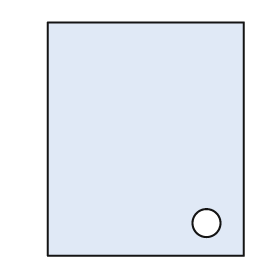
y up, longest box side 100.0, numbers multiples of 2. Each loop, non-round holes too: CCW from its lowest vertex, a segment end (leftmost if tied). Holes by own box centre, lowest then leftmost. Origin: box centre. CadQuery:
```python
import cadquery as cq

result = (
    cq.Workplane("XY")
    .moveTo(-42.0, -50.0)
    .lineTo(42.0, -50.0)
    .lineTo(42.0, 50.0)
    .lineTo(-42.0, 50.0)
    .close()
    .moveTo(26.0, -36.0)
    .circle(6.0)
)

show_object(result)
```